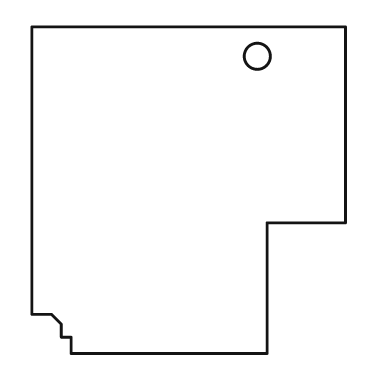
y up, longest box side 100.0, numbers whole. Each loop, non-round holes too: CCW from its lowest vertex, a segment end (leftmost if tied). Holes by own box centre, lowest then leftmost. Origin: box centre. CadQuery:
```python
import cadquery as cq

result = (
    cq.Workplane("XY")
    .moveTo(-36.0, -50.0)
    .lineTo(24.0, -50.0)
    .lineTo(24.0, -10.0)
    .lineTo(48.0, -10.0)
    .lineTo(48.0, 50.0)
    .lineTo(-48.0, 50.0)
    .lineTo(-48.0, -38.0)
    .lineTo(-42.0, -38.0)
    .lineTo(-39.0, -41.0)
    .lineTo(-39.0, -45.0)
    .lineTo(-36.0, -45.0)
    .close()
    .moveTo(21.0, 41.0)
    .circle(4.0)
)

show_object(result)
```